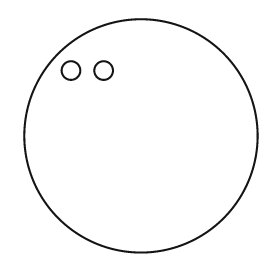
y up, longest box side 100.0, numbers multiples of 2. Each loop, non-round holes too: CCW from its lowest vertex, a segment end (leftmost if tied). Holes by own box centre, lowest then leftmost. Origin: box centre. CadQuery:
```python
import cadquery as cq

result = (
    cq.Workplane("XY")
    .moveTo(0.0, 0.0)
    .circle(50.0)
    .moveTo(-30.0, 28.0)
    .circle(4.0)
    .moveTo(-16.0, 28.0)
    .circle(4.0)
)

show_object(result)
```